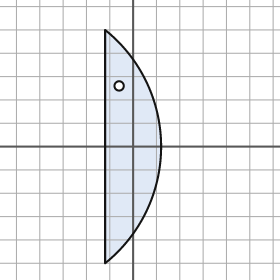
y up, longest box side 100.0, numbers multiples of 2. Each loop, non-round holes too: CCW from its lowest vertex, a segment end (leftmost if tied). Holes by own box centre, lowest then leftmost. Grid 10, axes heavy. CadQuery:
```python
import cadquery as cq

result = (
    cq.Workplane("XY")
    .moveTo(-12.0, -50.0)
    .threePointArc((12.0, 0.0), (-12.0, 50.0))
    .close()
    .moveTo(-6.0, 26.0)
    .circle(2.0)
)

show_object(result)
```